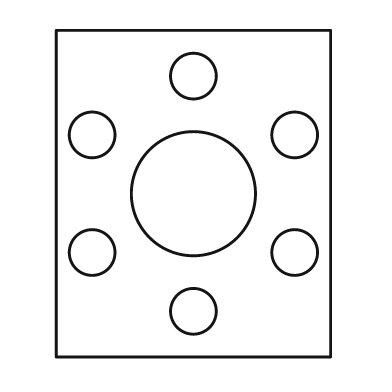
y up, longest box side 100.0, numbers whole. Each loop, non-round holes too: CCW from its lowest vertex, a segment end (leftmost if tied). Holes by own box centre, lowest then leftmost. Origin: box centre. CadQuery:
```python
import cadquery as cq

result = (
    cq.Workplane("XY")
    .moveTo(-42.0, -50.0)
    .lineTo(42.0, -50.0)
    .lineTo(42.0, 50.0)
    .lineTo(-42.0, 50.0)
    .close()
    .moveTo(0.0, -36.0)
    .circle(7.0)
    .moveTo(-31.0, -18.0)
    .circle(7.0)
    .moveTo(31.0, -18.0)
    .circle(7.0)
    .moveTo(0.0, 0.0)
    .circle(19.0)
    .moveTo(-31.0, 18.0)
    .circle(7.0)
    .moveTo(31.0, 18.0)
    .circle(7.0)
    .moveTo(0.0, 36.0)
    .circle(7.0)
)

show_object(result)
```